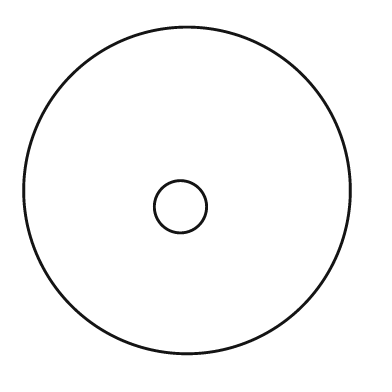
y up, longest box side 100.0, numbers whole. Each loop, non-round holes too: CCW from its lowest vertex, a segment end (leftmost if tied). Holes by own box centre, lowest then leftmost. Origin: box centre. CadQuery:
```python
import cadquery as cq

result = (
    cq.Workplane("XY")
    .moveTo(0.0, 0.0)
    .circle(50.0)
    .moveTo(-2.0, -5.0)
    .circle(8.0)
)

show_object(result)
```